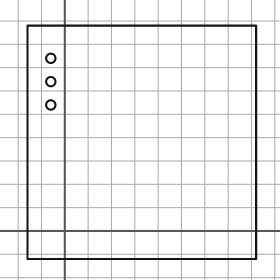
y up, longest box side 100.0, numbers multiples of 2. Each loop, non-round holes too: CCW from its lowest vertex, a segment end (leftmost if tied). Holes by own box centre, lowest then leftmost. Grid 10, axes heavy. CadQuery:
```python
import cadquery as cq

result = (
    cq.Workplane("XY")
    .moveTo(-16.0, -12.0)
    .lineTo(82.0, -12.0)
    .lineTo(82.0, 88.0)
    .lineTo(-16.0, 88.0)
    .close()
    .moveTo(-6.0, 54.0)
    .circle(2.0)
    .moveTo(-6.0, 64.0)
    .circle(2.0)
    .moveTo(-6.0, 74.0)
    .circle(2.0)
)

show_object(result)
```